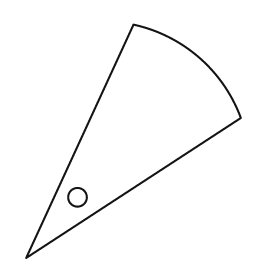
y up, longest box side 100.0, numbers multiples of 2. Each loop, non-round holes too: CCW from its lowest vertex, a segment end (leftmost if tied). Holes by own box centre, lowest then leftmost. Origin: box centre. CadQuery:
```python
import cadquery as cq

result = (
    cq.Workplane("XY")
    .moveTo(-46.0, -50.0)
    .lineTo(46.0, 10.0)
    .threePointArc((28.0, 36.0), (0.0, 50.0))
    .close()
    .moveTo(-24.0, -24.0)
    .circle(4.0)
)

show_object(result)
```